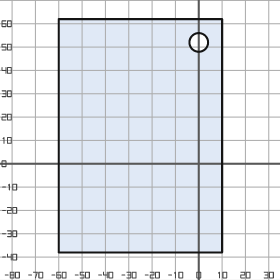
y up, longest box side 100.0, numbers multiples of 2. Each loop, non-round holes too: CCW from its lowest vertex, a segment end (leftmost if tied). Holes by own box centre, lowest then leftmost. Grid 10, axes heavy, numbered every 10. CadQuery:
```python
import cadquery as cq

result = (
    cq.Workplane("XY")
    .moveTo(-60.0, -38.0)
    .lineTo(10.0, -38.0)
    .lineTo(10.0, 62.0)
    .lineTo(-60.0, 62.0)
    .close()
    .moveTo(0.0, 52.0)
    .circle(4.0)
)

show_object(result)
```